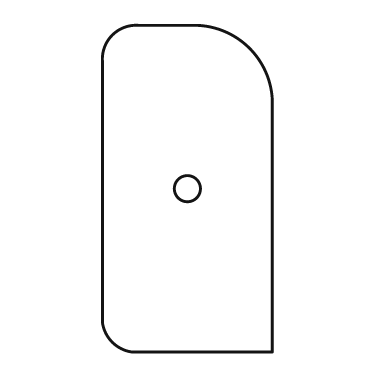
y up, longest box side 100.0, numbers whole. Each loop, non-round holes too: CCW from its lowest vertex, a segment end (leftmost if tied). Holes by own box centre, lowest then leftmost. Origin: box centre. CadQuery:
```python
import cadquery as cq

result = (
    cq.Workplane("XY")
    .moveTo(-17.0, -50.0)
    .lineTo(26.0, -50.0)
    .lineTo(26.0, 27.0)
    .threePointArc((19.0, 43.0), (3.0, 50.0))
    .lineTo(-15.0, 50.0)
    .threePointArc((-23.0, 47.0), (-26.0, 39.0))
    .lineTo(-26.0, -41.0)
    .threePointArc((-23.0, -47.0), (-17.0, -50.0))
    .close()
    .moveTo(0.0, 0.0)
    .circle(4.0)
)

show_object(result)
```